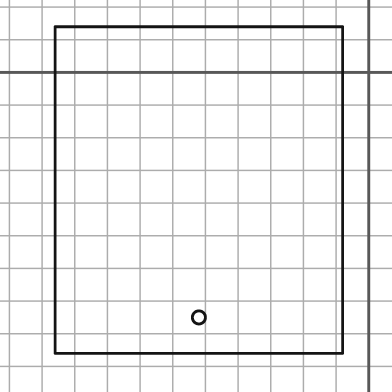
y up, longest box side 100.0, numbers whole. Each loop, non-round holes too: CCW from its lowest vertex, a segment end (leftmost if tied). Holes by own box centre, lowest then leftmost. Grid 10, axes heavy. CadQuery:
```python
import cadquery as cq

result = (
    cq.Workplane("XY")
    .moveTo(-96.0, -86.0)
    .lineTo(-8.0, -86.0)
    .lineTo(-8.0, 14.0)
    .lineTo(-96.0, 14.0)
    .close()
    .moveTo(-52.0, -75.0)
    .circle(2.0)
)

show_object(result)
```